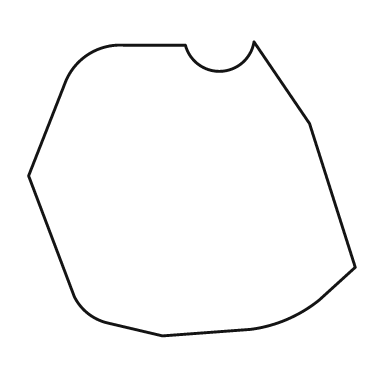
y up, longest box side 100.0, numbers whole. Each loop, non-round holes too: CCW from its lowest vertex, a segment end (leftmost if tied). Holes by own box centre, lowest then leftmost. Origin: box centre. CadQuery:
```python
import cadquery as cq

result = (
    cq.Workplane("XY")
    .moveTo(-9.0, -45.0)
    .lineTo(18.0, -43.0)
    .threePointArc((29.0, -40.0), (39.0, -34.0))
    .lineTo(50.0, -24.0)
    .lineTo(36.0, 20.0)
    .lineTo(19.0, 45.0)
    .threePointArc((9.0, 36.0), (-2.0, 44.0))
    .lineTo(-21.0, 44.0)
    .threePointArc((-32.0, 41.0), (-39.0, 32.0))
    .lineTo(-50.0, 4.0)
    .lineTo(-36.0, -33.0)
    .threePointArc((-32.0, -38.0), (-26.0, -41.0))
    .close()
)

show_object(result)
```